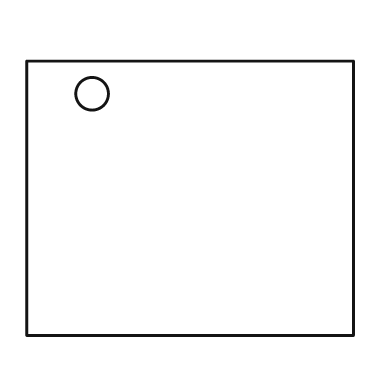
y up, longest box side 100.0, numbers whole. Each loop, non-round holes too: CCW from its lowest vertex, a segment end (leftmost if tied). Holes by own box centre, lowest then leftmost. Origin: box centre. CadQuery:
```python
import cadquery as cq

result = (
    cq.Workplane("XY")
    .moveTo(-50.0, -42.0)
    .lineTo(50.0, -42.0)
    .lineTo(50.0, 42.0)
    .lineTo(-50.0, 42.0)
    .close()
    .moveTo(-30.0, 32.0)
    .circle(5.0)
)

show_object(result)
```